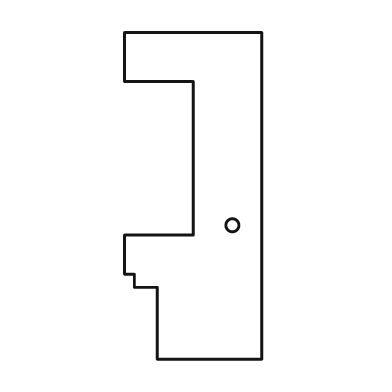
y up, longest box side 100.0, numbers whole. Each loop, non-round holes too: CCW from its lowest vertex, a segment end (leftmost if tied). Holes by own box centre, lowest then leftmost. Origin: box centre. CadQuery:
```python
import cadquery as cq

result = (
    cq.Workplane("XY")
    .moveTo(-11.0, -50.0)
    .lineTo(21.0, -50.0)
    .lineTo(21.0, 50.0)
    .lineTo(-21.0, 50.0)
    .lineTo(-21.0, 35.0)
    .lineTo(0.0, 35.0)
    .lineTo(0.0, -12.0)
    .lineTo(-21.0, -12.0)
    .lineTo(-21.0, -24.0)
    .lineTo(-18.0, -24.0)
    .lineTo(-18.0, -28.0)
    .lineTo(-11.0, -28.0)
    .close()
    .moveTo(12.0, -9.0)
    .circle(2.0)
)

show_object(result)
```